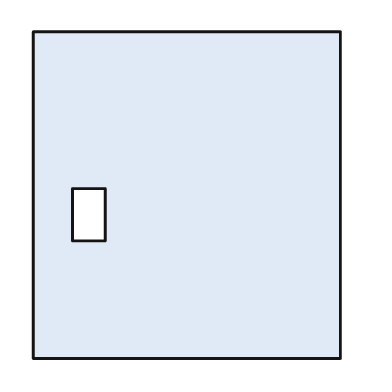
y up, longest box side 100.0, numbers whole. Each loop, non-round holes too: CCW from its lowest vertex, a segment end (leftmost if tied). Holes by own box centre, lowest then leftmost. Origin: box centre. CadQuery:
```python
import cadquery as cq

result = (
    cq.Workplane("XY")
    .moveTo(-47.0, -50.0)
    .lineTo(47.0, -50.0)
    .lineTo(47.0, 50.0)
    .lineTo(-47.0, 50.0)
    .close()
    .moveTo(-35.0, -14.0)
    .lineTo(-25.0, -14.0)
    .lineTo(-25.0, 2.0)
    .lineTo(-35.0, 2.0)
    .close()
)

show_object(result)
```